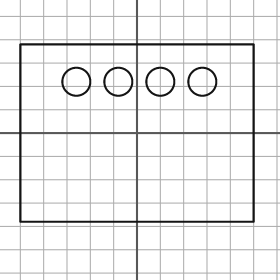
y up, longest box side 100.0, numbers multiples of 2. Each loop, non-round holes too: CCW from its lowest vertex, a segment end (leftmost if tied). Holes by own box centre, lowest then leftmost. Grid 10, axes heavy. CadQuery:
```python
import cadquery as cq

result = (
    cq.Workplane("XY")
    .moveTo(-50.0, -38.0)
    .lineTo(50.0, -38.0)
    .lineTo(50.0, 38.0)
    .lineTo(-50.0, 38.0)
    .close()
    .moveTo(-26.0, 22.0)
    .circle(6.0)
    .moveTo(-8.0, 22.0)
    .circle(6.0)
    .moveTo(10.0, 22.0)
    .circle(6.0)
    .moveTo(28.0, 22.0)
    .circle(6.0)
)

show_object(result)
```